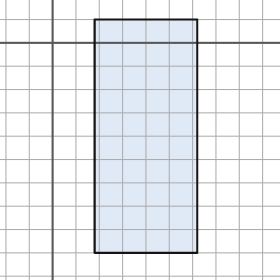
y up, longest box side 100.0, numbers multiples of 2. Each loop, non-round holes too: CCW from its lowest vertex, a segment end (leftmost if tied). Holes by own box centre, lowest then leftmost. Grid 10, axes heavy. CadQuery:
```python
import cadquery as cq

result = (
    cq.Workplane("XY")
    .moveTo(18.0, -90.0)
    .lineTo(62.0, -90.0)
    .lineTo(62.0, 10.0)
    .lineTo(18.0, 10.0)
    .close()
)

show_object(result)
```